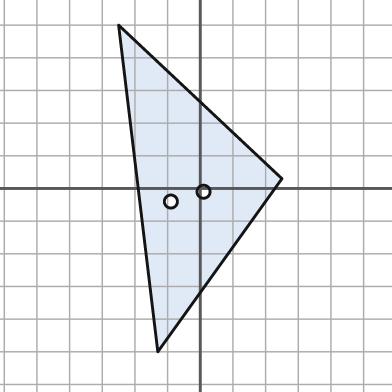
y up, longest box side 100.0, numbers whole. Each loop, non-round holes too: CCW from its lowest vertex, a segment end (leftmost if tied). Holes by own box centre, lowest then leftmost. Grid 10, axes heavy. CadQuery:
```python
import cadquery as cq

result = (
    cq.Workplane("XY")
    .moveTo(-13.0, -50.0)
    .lineTo(25.0, 3.0)
    .lineTo(-25.0, 50.0)
    .close()
    .moveTo(-9.0, -4.0)
    .circle(2.0)
    .moveTo(1.0, -1.0)
    .circle(2.0)
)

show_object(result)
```